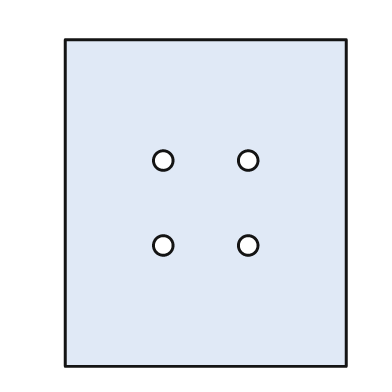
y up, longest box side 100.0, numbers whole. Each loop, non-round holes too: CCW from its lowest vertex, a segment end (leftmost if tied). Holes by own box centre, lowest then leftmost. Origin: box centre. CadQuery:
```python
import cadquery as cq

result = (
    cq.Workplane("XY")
    .moveTo(-43.0, -50.0)
    .lineTo(43.0, -50.0)
    .lineTo(43.0, 50.0)
    .lineTo(-43.0, 50.0)
    .close()
    .moveTo(-13.0, -13.0)
    .circle(3.0)
    .moveTo(13.0, -13.0)
    .circle(3.0)
    .moveTo(-13.0, 13.0)
    .circle(3.0)
    .moveTo(13.0, 13.0)
    .circle(3.0)
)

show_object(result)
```